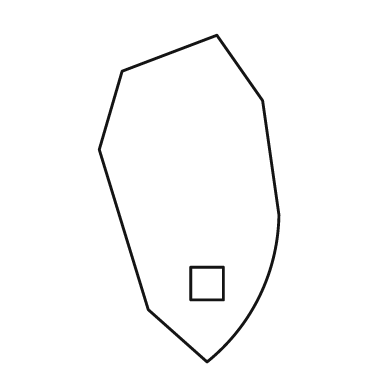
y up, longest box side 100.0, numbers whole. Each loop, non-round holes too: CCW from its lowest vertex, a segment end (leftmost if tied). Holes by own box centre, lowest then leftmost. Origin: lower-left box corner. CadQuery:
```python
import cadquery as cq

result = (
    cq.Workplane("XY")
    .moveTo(33.0, 0.0)
    .threePointArc((49.0, 20.0), (55.0, 45.0))
    .lineTo(50.0, 80.0)
    .lineTo(36.0, 100.0)
    .lineTo(7.0, 89.0)
    .lineTo(0.0, 65.0)
    .lineTo(15.0, 16.0)
    .close()
    .moveTo(28.0, 19.0)
    .lineTo(38.0, 19.0)
    .lineTo(38.0, 29.0)
    .lineTo(28.0, 29.0)
    .close()
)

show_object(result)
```